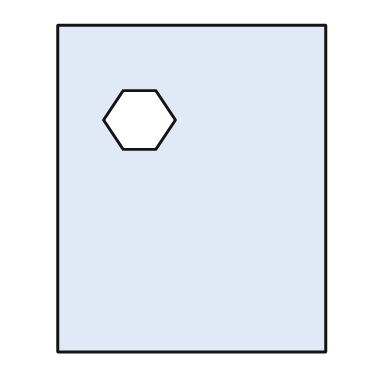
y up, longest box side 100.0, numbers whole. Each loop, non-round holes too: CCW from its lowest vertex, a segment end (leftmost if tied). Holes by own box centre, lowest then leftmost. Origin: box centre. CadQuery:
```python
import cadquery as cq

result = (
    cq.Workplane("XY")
    .moveTo(-41.0, -50.0)
    .lineTo(41.0, -50.0)
    .lineTo(41.0, 50.0)
    .lineTo(-41.0, 50.0)
    .close()
    .moveTo(-21.0, 12.0)
    .lineTo(-11.0, 12.0)
    .lineTo(-5.0, 21.0)
    .lineTo(-11.0, 30.0)
    .lineTo(-21.0, 30.0)
    .lineTo(-27.0, 21.0)
    .close()
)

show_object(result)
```